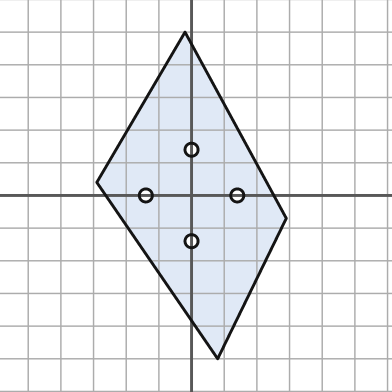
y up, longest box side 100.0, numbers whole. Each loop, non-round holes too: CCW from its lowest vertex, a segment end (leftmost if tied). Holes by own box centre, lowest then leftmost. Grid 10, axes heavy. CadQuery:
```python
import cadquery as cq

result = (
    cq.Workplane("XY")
    .moveTo(8.0, -50.0)
    .lineTo(29.0, -7.0)
    .lineTo(-2.0, 50.0)
    .lineTo(-29.0, 4.0)
    .close()
    .moveTo(0.0, -14.0)
    .circle(2.0)
    .moveTo(-14.0, 0.0)
    .circle(2.0)
    .moveTo(14.0, 0.0)
    .circle(2.0)
    .moveTo(0.0, 14.0)
    .circle(2.0)
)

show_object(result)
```